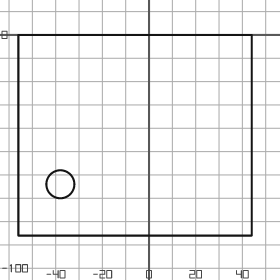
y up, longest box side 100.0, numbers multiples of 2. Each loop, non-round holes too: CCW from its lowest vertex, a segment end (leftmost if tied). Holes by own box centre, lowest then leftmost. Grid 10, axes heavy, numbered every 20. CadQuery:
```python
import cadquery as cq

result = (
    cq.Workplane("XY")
    .moveTo(-56.0, -86.0)
    .lineTo(44.0, -86.0)
    .lineTo(44.0, 0.0)
    .lineTo(-56.0, 0.0)
    .close()
    .moveTo(-38.0, -64.0)
    .circle(6.0)
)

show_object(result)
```